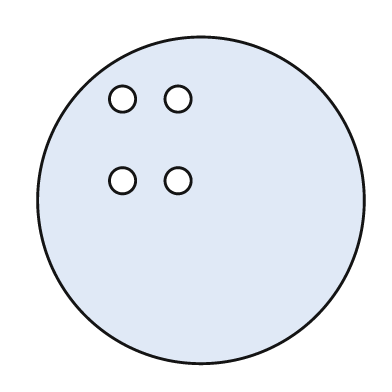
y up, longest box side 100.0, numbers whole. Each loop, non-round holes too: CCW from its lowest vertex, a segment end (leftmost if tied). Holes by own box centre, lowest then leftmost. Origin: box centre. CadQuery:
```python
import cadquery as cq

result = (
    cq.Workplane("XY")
    .moveTo(0.0, 0.0)
    .circle(50.0)
    .moveTo(-24.0, 6.0)
    .circle(4.0)
    .moveTo(-7.0, 6.0)
    .circle(4.0)
    .moveTo(-24.0, 31.0)
    .circle(4.0)
    .moveTo(-7.0, 31.0)
    .circle(4.0)
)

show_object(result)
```